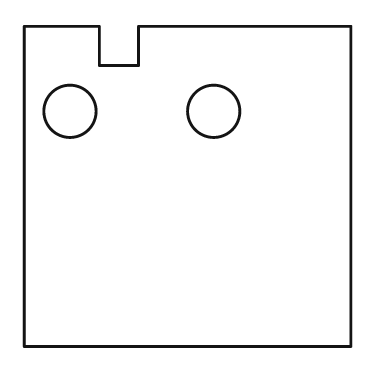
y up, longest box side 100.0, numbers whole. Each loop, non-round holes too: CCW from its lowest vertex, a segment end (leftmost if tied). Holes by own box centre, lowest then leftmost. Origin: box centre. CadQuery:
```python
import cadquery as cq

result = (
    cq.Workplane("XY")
    .moveTo(-50.0, -49.0)
    .lineTo(50.0, -49.0)
    .lineTo(50.0, 49.0)
    .lineTo(-15.0, 49.0)
    .lineTo(-15.0, 37.0)
    .lineTo(-27.0, 37.0)
    .lineTo(-27.0, 49.0)
    .lineTo(-50.0, 49.0)
    .close()
    .moveTo(-36.0, 23.0)
    .circle(8.0)
    .moveTo(8.0, 23.0)
    .circle(8.0)
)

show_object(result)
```